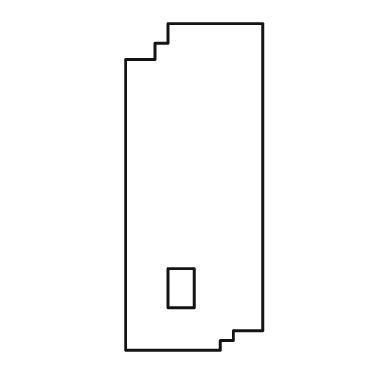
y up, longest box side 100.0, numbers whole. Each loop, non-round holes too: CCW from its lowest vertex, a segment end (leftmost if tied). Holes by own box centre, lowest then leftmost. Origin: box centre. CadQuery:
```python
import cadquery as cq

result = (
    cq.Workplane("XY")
    .moveTo(-21.0, -50.0)
    .lineTo(8.0, -50.0)
    .lineTo(8.0, -47.0)
    .lineTo(12.0, -47.0)
    .lineTo(12.0, -44.0)
    .lineTo(21.0, -44.0)
    .lineTo(21.0, 50.0)
    .lineTo(-8.0, 50.0)
    .lineTo(-8.0, 44.0)
    .lineTo(-12.0, 44.0)
    .lineTo(-12.0, 39.0)
    .lineTo(-21.0, 39.0)
    .close()
    .moveTo(-8.0, -37.0)
    .lineTo(0.0, -37.0)
    .lineTo(0.0, -25.0)
    .lineTo(-8.0, -25.0)
    .close()
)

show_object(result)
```